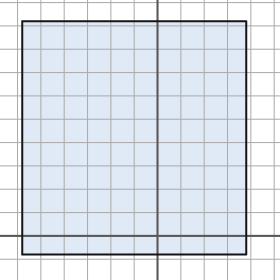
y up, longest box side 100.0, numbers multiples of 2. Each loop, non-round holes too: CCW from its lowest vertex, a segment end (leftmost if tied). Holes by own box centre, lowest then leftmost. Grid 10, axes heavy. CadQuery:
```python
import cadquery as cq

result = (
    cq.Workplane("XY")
    .moveTo(-58.0, -8.0)
    .lineTo(38.0, -8.0)
    .lineTo(38.0, 92.0)
    .lineTo(-58.0, 92.0)
    .close()
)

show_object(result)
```